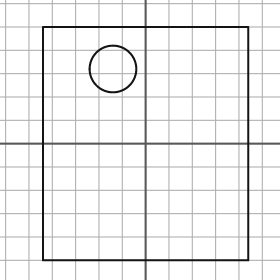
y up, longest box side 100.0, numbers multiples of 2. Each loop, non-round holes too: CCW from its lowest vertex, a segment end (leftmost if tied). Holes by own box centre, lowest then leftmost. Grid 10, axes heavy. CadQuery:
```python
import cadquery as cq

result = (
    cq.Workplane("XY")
    .moveTo(-44.0, -50.0)
    .lineTo(44.0, -50.0)
    .lineTo(44.0, 50.0)
    .lineTo(-44.0, 50.0)
    .close()
    .moveTo(-14.0, 32.0)
    .circle(10.0)
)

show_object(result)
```